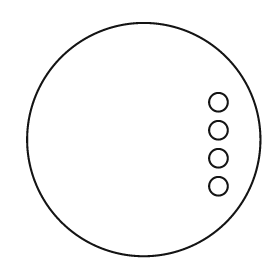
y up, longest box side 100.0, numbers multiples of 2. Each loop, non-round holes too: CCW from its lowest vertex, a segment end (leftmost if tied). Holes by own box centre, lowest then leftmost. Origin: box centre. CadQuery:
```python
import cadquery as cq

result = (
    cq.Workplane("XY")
    .moveTo(0.0, 0.0)
    .circle(50.0)
    .moveTo(32.0, -20.0)
    .circle(4.0)
    .moveTo(32.0, -8.0)
    .circle(4.0)
    .moveTo(32.0, 4.0)
    .circle(4.0)
    .moveTo(32.0, 16.0)
    .circle(4.0)
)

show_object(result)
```